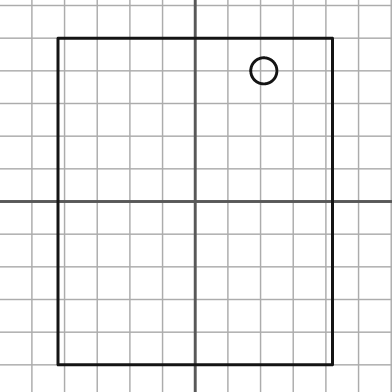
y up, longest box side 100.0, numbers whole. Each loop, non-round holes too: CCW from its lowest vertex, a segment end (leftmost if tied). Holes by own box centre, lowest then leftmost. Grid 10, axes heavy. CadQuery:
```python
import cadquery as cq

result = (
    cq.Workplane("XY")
    .moveTo(-42.0, -50.0)
    .lineTo(42.0, -50.0)
    .lineTo(42.0, 50.0)
    .lineTo(-42.0, 50.0)
    .close()
    .moveTo(21.0, 40.0)
    .circle(4.0)
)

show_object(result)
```